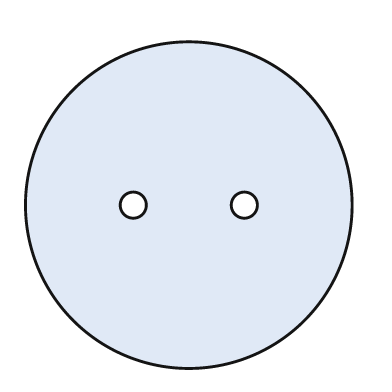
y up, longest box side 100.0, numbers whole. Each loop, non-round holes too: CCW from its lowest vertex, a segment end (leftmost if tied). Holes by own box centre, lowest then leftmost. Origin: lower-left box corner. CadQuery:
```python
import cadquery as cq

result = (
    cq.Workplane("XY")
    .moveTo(50.0, 50.0)
    .circle(50.0)
    .moveTo(33.0, 50.0)
    .circle(4.0)
    .moveTo(67.0, 50.0)
    .circle(4.0)
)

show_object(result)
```